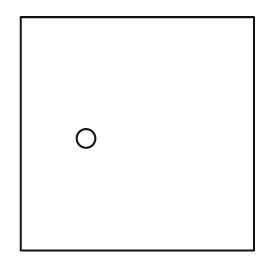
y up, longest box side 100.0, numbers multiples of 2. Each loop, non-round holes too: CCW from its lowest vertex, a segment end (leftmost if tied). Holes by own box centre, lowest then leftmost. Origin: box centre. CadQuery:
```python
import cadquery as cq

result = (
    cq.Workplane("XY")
    .moveTo(-50.0, -50.0)
    .lineTo(50.0, -50.0)
    .lineTo(50.0, 50.0)
    .lineTo(-50.0, 50.0)
    .close()
    .moveTo(-22.0, -2.0)
    .circle(4.0)
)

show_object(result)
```